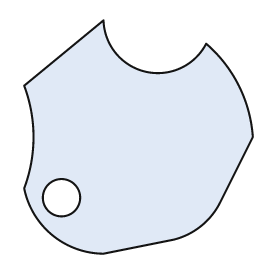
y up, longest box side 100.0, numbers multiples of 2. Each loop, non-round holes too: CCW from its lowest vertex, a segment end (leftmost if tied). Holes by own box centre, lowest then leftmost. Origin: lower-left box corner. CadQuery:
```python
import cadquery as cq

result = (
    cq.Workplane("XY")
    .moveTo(34.0, 0.0)
    .lineTo(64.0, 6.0)
    .threePointArc((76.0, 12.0), (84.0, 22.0))
    .lineTo(98.0, 50.0)
    .threePointArc((92.0, 72.0), (78.0, 90.0))
    .threePointArc((52.0, 78.0), (34.0, 100.0))
    .lineTo(0.0, 72.0)
    .threePointArc((4.0, 50.0), (0.0, 28.0))
    .threePointArc((12.0, 8.0), (34.0, 0.0))
    .close()
    .moveTo(16.0, 24.0)
    .circle(8.0)
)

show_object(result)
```